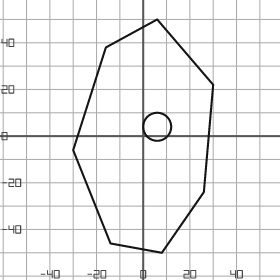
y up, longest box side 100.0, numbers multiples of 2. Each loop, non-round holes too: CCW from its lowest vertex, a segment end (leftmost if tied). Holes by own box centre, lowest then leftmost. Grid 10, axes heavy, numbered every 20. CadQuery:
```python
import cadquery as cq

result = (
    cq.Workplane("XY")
    .moveTo(8.0, -50.0)
    .lineTo(26.0, -24.0)
    .lineTo(30.0, 22.0)
    .lineTo(6.0, 50.0)
    .lineTo(-16.0, 38.0)
    .lineTo(-30.0, -6.0)
    .lineTo(-14.0, -46.0)
    .close()
    .moveTo(6.0, 4.0)
    .circle(6.0)
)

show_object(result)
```